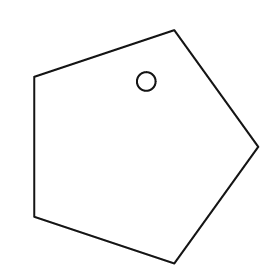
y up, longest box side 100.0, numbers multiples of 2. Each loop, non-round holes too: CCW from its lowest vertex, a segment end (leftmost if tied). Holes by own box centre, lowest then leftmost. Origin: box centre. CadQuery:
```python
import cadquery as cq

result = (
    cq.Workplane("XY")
    .moveTo(12.0, -50.0)
    .lineTo(48.0, 0.0)
    .lineTo(12.0, 50.0)
    .lineTo(-48.0, 30.0)
    .lineTo(-48.0, -30.0)
    .close()
    .moveTo(0.0, 28.0)
    .circle(4.0)
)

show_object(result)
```